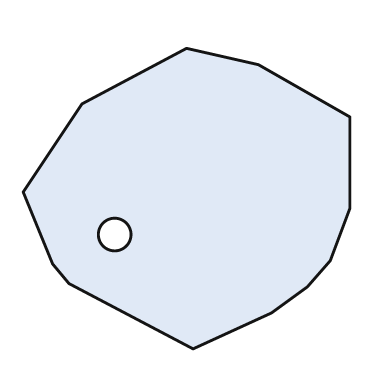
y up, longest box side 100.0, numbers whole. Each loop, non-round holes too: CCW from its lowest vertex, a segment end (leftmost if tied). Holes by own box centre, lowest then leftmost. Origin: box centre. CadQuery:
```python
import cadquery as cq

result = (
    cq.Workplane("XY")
    .moveTo(2.0, -46.0)
    .lineTo(26.0, -35.0)
    .lineTo(37.0, -27.0)
    .lineTo(44.0, -19.0)
    .lineTo(50.0, -3.0)
    .lineTo(50.0, 25.0)
    .lineTo(22.0, 41.0)
    .lineTo(0.0, 46.0)
    .lineTo(-32.0, 29.0)
    .lineTo(-50.0, 2.0)
    .lineTo(-41.0, -20.0)
    .lineTo(-36.0, -26.0)
    .close()
    .moveTo(-22.0, -11.0)
    .circle(5.0)
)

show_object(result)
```